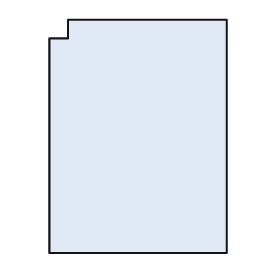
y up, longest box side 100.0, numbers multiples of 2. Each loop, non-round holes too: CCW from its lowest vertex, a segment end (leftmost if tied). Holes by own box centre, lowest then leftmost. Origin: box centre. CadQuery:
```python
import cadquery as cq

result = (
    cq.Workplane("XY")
    .moveTo(-38.0, -50.0)
    .lineTo(38.0, -50.0)
    .lineTo(38.0, 50.0)
    .lineTo(-30.0, 50.0)
    .lineTo(-30.0, 42.0)
    .lineTo(-38.0, 42.0)
    .close()
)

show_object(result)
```